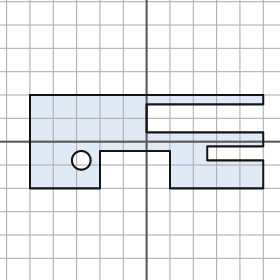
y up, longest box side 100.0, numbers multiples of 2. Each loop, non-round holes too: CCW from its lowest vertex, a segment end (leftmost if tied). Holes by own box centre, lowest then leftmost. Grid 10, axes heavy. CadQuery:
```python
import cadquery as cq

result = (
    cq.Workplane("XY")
    .moveTo(-50.0, -20.0)
    .lineTo(-20.0, -20.0)
    .lineTo(-20.0, -4.0)
    .lineTo(10.0, -4.0)
    .lineTo(10.0, -20.0)
    .lineTo(50.0, -20.0)
    .lineTo(50.0, -8.0)
    .lineTo(26.0, -8.0)
    .lineTo(26.0, -2.0)
    .lineTo(50.0, -2.0)
    .lineTo(50.0, 4.0)
    .lineTo(0.0, 4.0)
    .lineTo(0.0, 16.0)
    .lineTo(50.0, 16.0)
    .lineTo(50.0, 20.0)
    .lineTo(-50.0, 20.0)
    .close()
    .moveTo(-28.0, -8.0)
    .circle(4.0)
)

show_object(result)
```